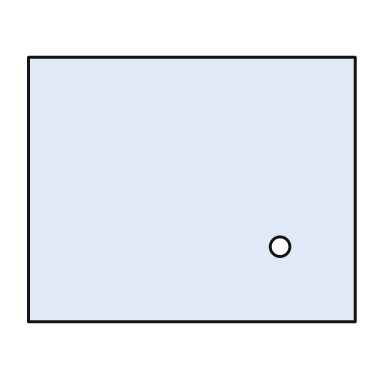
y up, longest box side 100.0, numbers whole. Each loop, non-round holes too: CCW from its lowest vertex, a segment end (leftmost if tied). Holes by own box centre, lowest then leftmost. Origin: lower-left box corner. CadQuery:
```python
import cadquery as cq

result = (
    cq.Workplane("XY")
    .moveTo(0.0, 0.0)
    .lineTo(100.0, 0.0)
    .lineTo(100.0, 81.0)
    .lineTo(0.0, 81.0)
    .close()
    .moveTo(77.0, 23.0)
    .circle(3.0)
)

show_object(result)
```